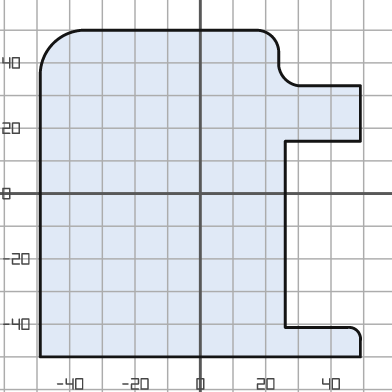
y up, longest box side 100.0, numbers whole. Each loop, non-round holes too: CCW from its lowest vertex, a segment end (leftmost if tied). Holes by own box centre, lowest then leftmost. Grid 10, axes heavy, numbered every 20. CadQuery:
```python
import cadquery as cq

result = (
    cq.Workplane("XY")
    .moveTo(-49.0, -50.0)
    .lineTo(49.0, -50.0)
    .lineTo(49.0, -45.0)
    .threePointArc((48.0, -42.0), (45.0, -41.0))
    .lineTo(26.0, -41.0)
    .lineTo(26.0, 16.0)
    .lineTo(49.0, 16.0)
    .lineTo(49.0, 33.0)
    .lineTo(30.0, 33.0)
    .threePointArc((26.0, 35.0), (24.0, 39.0))
    .lineTo(24.0, 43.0)
    .threePointArc((22.0, 48.0), (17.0, 50.0))
    .lineTo(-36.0, 50.0)
    .threePointArc((-45.0, 46.0), (-49.0, 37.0))
    .close()
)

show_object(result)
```